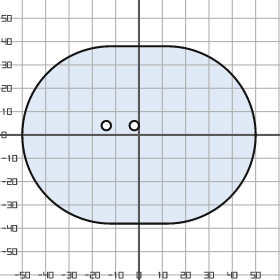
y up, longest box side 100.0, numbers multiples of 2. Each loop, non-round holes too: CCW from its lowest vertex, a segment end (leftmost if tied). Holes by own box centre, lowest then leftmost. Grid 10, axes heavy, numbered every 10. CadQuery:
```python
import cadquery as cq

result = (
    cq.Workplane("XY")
    .moveTo(-12.0, -38.0)
    .lineTo(12.0, -38.0)
    .threePointArc((50.0, 0.0), (12.0, 38.0))
    .lineTo(-12.0, 38.0)
    .threePointArc((-50.0, 0.0), (-12.0, -38.0))
    .close()
    .moveTo(-14.0, 4.0)
    .circle(2.0)
    .moveTo(-2.0, 4.0)
    .circle(2.0)
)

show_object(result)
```